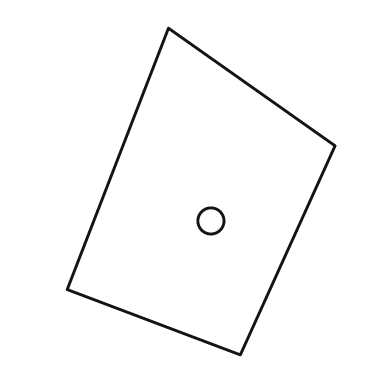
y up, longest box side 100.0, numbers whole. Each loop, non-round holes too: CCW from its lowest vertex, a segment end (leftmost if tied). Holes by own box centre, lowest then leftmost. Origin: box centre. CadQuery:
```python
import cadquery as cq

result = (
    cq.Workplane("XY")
    .moveTo(12.0, -50.0)
    .lineTo(41.0, 14.0)
    .lineTo(-10.0, 50.0)
    .lineTo(-41.0, -30.0)
    .close()
    .moveTo(3.0, -9.0)
    .circle(4.0)
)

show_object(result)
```